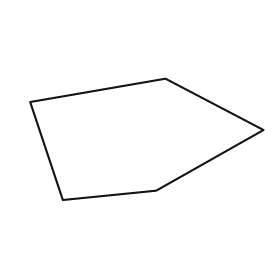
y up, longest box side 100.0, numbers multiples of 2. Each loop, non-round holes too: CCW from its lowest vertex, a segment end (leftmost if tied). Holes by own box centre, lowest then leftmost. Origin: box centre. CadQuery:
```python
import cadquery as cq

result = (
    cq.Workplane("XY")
    .moveTo(-36.0, -26.0)
    .lineTo(4.0, -22.0)
    .lineTo(50.0, 4.0)
    .lineTo(8.0, 26.0)
    .lineTo(-50.0, 16.0)
    .close()
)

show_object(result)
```